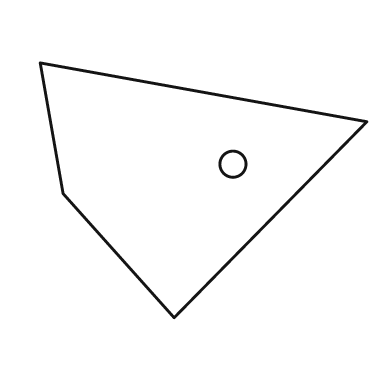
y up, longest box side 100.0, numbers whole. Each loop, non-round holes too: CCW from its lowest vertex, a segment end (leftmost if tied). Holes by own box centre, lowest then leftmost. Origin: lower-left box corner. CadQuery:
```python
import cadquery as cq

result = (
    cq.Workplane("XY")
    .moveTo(41.0, 0.0)
    .lineTo(100.0, 60.0)
    .lineTo(0.0, 78.0)
    .lineTo(7.0, 38.0)
    .close()
    .moveTo(59.0, 47.0)
    .circle(4.0)
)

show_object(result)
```